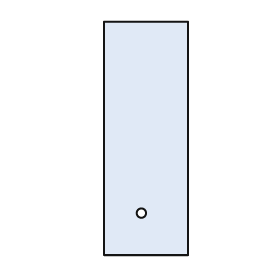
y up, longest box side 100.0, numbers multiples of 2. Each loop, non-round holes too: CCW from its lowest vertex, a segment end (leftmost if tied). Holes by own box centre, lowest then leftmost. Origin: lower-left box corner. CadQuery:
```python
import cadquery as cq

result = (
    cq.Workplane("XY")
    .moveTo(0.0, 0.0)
    .lineTo(36.0, 0.0)
    .lineTo(36.0, 100.0)
    .lineTo(0.0, 100.0)
    .close()
    .moveTo(16.0, 18.0)
    .circle(2.0)
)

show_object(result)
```